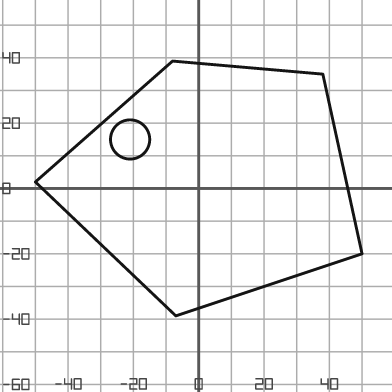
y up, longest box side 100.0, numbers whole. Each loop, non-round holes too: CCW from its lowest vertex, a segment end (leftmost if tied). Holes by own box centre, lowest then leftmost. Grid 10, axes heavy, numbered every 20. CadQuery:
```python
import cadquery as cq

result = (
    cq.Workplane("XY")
    .moveTo(-7.0, -39.0)
    .lineTo(50.0, -20.0)
    .lineTo(38.0, 35.0)
    .lineTo(-8.0, 39.0)
    .lineTo(-50.0, 2.0)
    .close()
    .moveTo(-21.0, 15.0)
    .circle(6.0)
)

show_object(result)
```